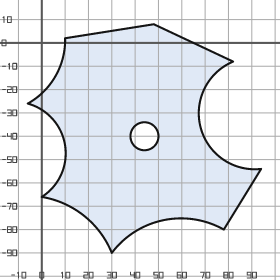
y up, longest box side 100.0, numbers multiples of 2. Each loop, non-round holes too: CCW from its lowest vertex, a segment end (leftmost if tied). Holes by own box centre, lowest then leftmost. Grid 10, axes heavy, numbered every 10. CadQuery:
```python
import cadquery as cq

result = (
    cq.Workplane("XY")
    .moveTo(30.0, -90.0)
    .threePointArc((52.0, -76.0), (78.0, -80.0))
    .lineTo(94.0, -54.0)
    .threePointArc((68.0, -36.0), (82.0, -8.0))
    .lineTo(48.0, 8.0)
    .lineTo(10.0, 2.0)
    .threePointArc((6.0, -14.0), (-6.0, -26.0))
    .threePointArc((10.0, -44.0), (0.0, -66.0))
    .threePointArc((18.0, -74.0), (30.0, -90.0))
    .close()
    .moveTo(44.0, -40.0)
    .circle(6.0)
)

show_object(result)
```